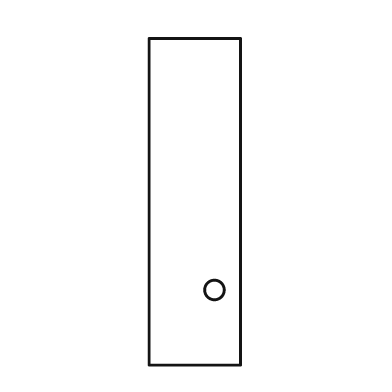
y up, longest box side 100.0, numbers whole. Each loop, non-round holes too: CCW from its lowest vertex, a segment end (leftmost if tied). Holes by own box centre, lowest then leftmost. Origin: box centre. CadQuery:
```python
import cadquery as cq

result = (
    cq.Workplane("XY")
    .moveTo(-14.0, -50.0)
    .lineTo(14.0, -50.0)
    .lineTo(14.0, 50.0)
    .lineTo(-14.0, 50.0)
    .close()
    .moveTo(6.0, -27.0)
    .circle(3.0)
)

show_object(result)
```